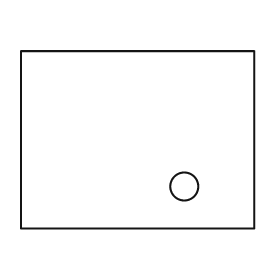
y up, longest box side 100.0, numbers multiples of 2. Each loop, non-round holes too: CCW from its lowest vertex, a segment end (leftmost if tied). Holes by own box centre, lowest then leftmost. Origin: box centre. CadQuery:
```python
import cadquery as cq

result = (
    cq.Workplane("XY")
    .moveTo(-50.0, -38.0)
    .lineTo(50.0, -38.0)
    .lineTo(50.0, 38.0)
    .lineTo(-50.0, 38.0)
    .close()
    .moveTo(20.0, -20.0)
    .circle(6.0)
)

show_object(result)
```